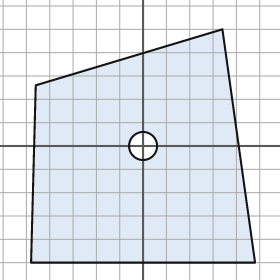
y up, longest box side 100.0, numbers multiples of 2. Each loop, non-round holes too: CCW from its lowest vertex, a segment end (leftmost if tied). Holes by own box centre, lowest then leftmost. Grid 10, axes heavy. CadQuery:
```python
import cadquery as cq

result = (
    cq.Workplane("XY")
    .moveTo(-48.0, -50.0)
    .lineTo(48.0, -50.0)
    .lineTo(34.0, 50.0)
    .lineTo(-46.0, 26.0)
    .close()
    .moveTo(0.0, 0.0)
    .circle(6.0)
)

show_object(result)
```